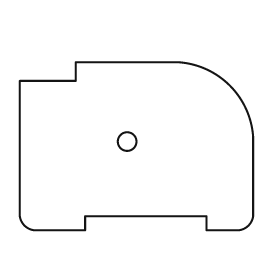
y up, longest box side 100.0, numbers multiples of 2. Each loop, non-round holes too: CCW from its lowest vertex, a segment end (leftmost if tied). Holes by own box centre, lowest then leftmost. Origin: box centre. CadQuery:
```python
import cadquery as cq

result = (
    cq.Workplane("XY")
    .moveTo(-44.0, -36.0)
    .lineTo(-22.0, -36.0)
    .lineTo(-22.0, -30.0)
    .lineTo(30.0, -30.0)
    .lineTo(30.0, -36.0)
    .lineTo(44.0, -36.0)
    .threePointArc((48.0, -34.0), (50.0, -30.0))
    .lineTo(50.0, 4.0)
    .threePointArc((40.0, 26.0), (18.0, 36.0))
    .lineTo(-26.0, 36.0)
    .lineTo(-26.0, 28.0)
    .lineTo(-50.0, 28.0)
    .lineTo(-50.0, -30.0)
    .threePointArc((-48.0, -34.0), (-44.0, -36.0))
    .close()
    .moveTo(-4.0, 2.0)
    .circle(4.0)
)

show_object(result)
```